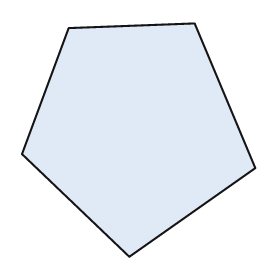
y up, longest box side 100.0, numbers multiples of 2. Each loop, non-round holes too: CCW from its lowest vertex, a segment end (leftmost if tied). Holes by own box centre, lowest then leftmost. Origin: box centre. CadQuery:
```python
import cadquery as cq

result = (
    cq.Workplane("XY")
    .moveTo(-4.0, -50.0)
    .lineTo(50.0, -12.0)
    .lineTo(24.0, 50.0)
    .lineTo(-30.0, 48.0)
    .lineTo(-50.0, -6.0)
    .close()
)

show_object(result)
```